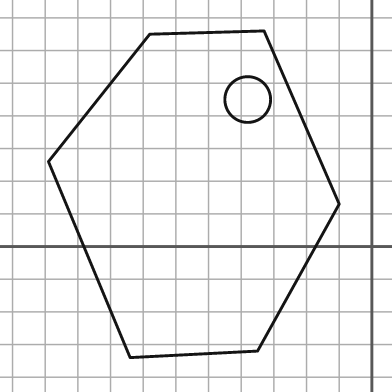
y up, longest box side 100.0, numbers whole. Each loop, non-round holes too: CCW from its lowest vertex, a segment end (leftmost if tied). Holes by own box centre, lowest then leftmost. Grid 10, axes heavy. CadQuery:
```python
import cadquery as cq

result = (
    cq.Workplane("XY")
    .moveTo(-74.0, -34.0)
    .lineTo(-35.0, -32.0)
    .lineTo(-10.0, 13.0)
    .lineTo(-33.0, 66.0)
    .lineTo(-68.0, 65.0)
    .lineTo(-99.0, 26.0)
    .close()
    .moveTo(-38.0, 45.0)
    .circle(7.0)
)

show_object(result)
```